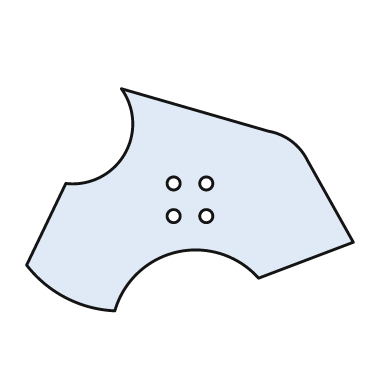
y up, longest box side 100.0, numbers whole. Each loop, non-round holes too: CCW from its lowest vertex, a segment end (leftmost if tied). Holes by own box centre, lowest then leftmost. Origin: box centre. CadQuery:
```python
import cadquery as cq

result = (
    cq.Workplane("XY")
    .moveTo(-23.0, -34.0)
    .threePointArc((-4.0, -16.0), (21.0, -24.0))
    .lineTo(50.0, -13.0)
    .lineTo(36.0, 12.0)
    .threePointArc((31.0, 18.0), (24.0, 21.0))
    .lineTo(-21.0, 34.0)
    .threePointArc((-20.0, 14.0), (-38.0, 5.0))
    .lineTo(-50.0, -20.0)
    .threePointArc((-38.0, -30.0), (-23.0, -34.0))
    .close()
    .moveTo(-5.0, -5.0)
    .circle(2.0)
    .moveTo(5.0, -5.0)
    .circle(2.0)
    .moveTo(-5.0, 5.0)
    .circle(2.0)
    .moveTo(5.0, 5.0)
    .circle(2.0)
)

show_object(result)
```